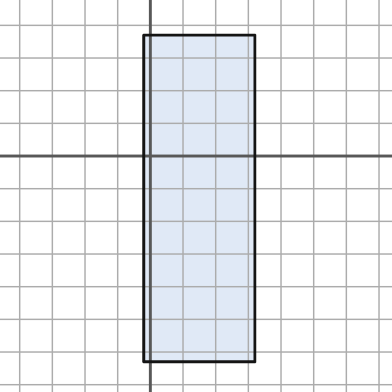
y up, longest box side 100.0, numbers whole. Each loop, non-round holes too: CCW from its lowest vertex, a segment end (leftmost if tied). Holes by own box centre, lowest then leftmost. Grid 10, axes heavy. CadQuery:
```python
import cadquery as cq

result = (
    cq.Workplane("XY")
    .moveTo(-2.0, -63.0)
    .lineTo(32.0, -63.0)
    .lineTo(32.0, 37.0)
    .lineTo(-2.0, 37.0)
    .close()
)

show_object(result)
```